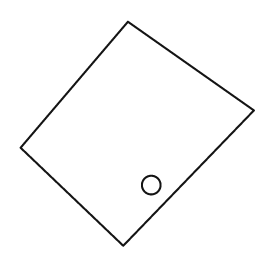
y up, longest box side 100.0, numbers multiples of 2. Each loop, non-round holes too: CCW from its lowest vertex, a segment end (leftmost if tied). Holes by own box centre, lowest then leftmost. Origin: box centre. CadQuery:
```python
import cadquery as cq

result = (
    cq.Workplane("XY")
    .moveTo(-6.0, -48.0)
    .lineTo(50.0, 10.0)
    .lineTo(-4.0, 48.0)
    .lineTo(-50.0, -6.0)
    .close()
    .moveTo(6.0, -22.0)
    .circle(4.0)
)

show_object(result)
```